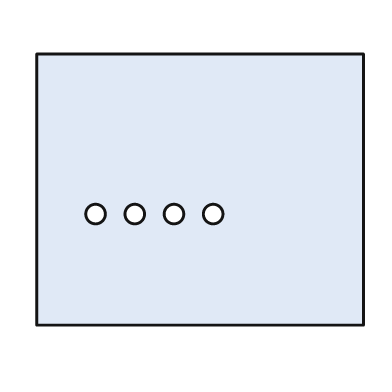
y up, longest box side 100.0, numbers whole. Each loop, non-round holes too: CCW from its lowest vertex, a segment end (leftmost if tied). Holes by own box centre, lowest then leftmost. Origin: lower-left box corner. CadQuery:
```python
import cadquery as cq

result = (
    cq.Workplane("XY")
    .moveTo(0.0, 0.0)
    .lineTo(100.0, 0.0)
    .lineTo(100.0, 83.0)
    .lineTo(0.0, 83.0)
    .close()
    .moveTo(18.0, 34.0)
    .circle(3.0)
    .moveTo(30.0, 34.0)
    .circle(3.0)
    .moveTo(42.0, 34.0)
    .circle(3.0)
    .moveTo(54.0, 34.0)
    .circle(3.0)
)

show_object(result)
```